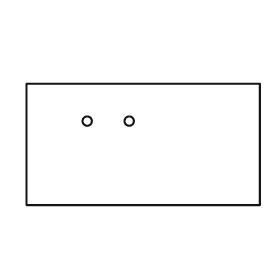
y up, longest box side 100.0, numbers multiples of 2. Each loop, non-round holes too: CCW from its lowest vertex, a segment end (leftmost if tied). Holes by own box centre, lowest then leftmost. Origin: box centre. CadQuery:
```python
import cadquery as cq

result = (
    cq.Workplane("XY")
    .moveTo(-50.0, -26.0)
    .lineTo(50.0, -26.0)
    .lineTo(50.0, 26.0)
    .lineTo(-50.0, 26.0)
    .close()
    .moveTo(-24.0, 10.0)
    .circle(2.0)
    .moveTo(-6.0, 10.0)
    .circle(2.0)
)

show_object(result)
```